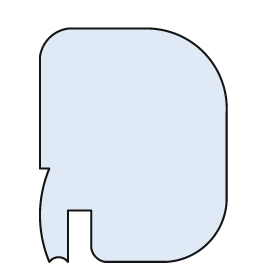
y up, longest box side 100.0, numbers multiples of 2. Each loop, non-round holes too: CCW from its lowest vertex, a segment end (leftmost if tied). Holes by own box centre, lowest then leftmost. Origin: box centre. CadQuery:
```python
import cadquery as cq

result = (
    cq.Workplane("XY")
    .moveTo(-36.0, -50.0)
    .threePointArc((-32.0, -48.0), (-28.0, -50.0))
    .lineTo(-28.0, -28.0)
    .lineTo(-18.0, -28.0)
    .lineTo(-18.0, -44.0)
    .threePointArc((-16.0, -48.0), (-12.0, -50.0))
    .lineTo(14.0, -50.0)
    .threePointArc((32.0, -42.0), (40.0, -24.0))
    .lineTo(40.0, 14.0)
    .threePointArc((30.0, 40.0), (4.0, 50.0))
    .lineTo(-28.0, 50.0)
    .threePointArc((-36.0, 46.0), (-40.0, 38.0))
    .lineTo(-40.0, -10.0)
    .lineTo(-36.0, -10.0)
    .threePointArc((-40.0, -30.0), (-36.0, -50.0))
    .close()
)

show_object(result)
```